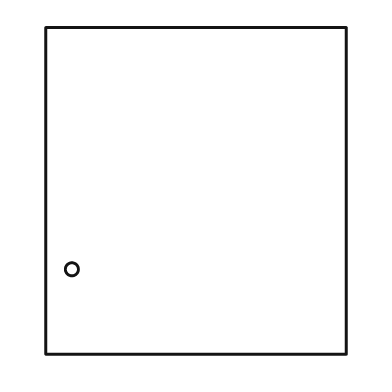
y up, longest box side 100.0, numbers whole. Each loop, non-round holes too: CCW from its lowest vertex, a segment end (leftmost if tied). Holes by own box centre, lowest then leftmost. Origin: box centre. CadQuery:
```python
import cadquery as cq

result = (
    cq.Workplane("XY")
    .moveTo(-46.0, -50.0)
    .lineTo(46.0, -50.0)
    .lineTo(46.0, 50.0)
    .lineTo(-46.0, 50.0)
    .close()
    .moveTo(-38.0, -24.0)
    .circle(2.0)
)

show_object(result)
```